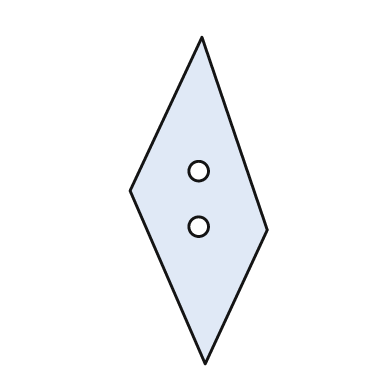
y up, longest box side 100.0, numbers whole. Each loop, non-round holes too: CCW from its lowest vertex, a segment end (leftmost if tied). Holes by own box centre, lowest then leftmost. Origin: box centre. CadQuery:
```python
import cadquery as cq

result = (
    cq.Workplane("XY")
    .moveTo(2.0, -50.0)
    .lineTo(21.0, -9.0)
    .lineTo(1.0, 50.0)
    .lineTo(-21.0, 3.0)
    .close()
    .moveTo(0.0, -8.0)
    .circle(3.0)
    .moveTo(0.0, 9.0)
    .circle(3.0)
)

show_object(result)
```